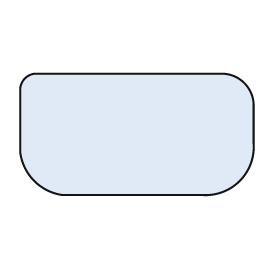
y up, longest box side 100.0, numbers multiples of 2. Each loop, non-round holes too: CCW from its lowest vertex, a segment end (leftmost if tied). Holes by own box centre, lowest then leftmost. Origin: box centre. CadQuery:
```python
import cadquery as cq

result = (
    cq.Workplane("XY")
    .moveTo(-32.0, -26.0)
    .lineTo(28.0, -26.0)
    .threePointArc((44.0, -20.0), (50.0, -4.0))
    .lineTo(50.0, 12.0)
    .threePointArc((46.0, 22.0), (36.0, 26.0))
    .lineTo(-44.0, 26.0)
    .threePointArc((-48.0, 24.0), (-50.0, 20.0))
    .lineTo(-50.0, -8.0)
    .threePointArc((-44.0, -20.0), (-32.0, -26.0))
    .close()
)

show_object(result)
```